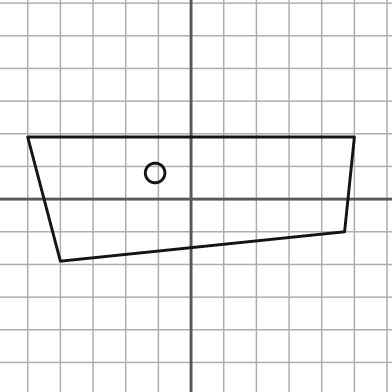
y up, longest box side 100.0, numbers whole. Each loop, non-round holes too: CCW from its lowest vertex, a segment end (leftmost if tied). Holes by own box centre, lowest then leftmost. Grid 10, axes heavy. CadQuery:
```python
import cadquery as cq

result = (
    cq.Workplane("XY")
    .moveTo(-40.0, -19.0)
    .lineTo(47.0, -10.0)
    .lineTo(50.0, 19.0)
    .lineTo(-50.0, 19.0)
    .close()
    .moveTo(-11.0, 8.0)
    .circle(3.0)
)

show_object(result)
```